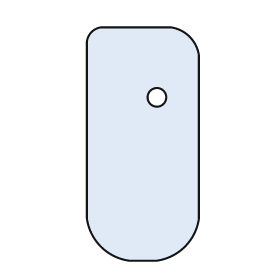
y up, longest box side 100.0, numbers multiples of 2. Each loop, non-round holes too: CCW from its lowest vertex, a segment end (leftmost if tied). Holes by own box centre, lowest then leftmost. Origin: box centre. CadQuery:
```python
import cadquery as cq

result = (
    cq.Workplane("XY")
    .moveTo(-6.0, -50.0)
    .lineTo(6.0, -50.0)
    .threePointArc((18.0, -44.0), (24.0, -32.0))
    .lineTo(24.0, 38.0)
    .threePointArc((20.0, 46.0), (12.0, 50.0))
    .lineTo(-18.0, 50.0)
    .threePointArc((-22.0, 48.0), (-24.0, 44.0))
    .lineTo(-24.0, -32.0)
    .threePointArc((-18.0, -44.0), (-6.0, -50.0))
    .close()
    .moveTo(6.0, 20.0)
    .circle(4.0)
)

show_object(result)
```